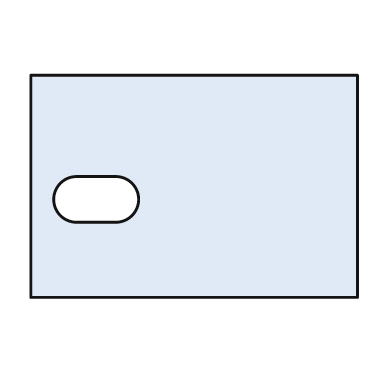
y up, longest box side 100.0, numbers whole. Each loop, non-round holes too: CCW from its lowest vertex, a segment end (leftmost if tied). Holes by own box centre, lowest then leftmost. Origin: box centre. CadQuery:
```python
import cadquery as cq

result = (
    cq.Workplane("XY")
    .moveTo(-50.0, -34.0)
    .lineTo(50.0, -34.0)
    .lineTo(50.0, 34.0)
    .lineTo(-50.0, 34.0)
    .close()
    .moveTo(-36.0, -11.0)
    .lineTo(-24.0, -11.0)
    .threePointArc((-17.0, -4.0), (-24.0, 3.0))
    .lineTo(-36.0, 3.0)
    .threePointArc((-43.0, -4.0), (-36.0, -11.0))
    .close()
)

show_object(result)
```